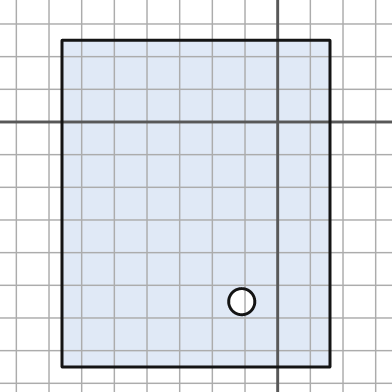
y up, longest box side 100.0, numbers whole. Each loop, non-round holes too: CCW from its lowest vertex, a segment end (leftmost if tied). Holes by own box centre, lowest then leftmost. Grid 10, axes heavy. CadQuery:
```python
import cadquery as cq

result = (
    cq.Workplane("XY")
    .moveTo(-66.0, -75.0)
    .lineTo(16.0, -75.0)
    .lineTo(16.0, 25.0)
    .lineTo(-66.0, 25.0)
    .close()
    .moveTo(-11.0, -55.0)
    .circle(4.0)
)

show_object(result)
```